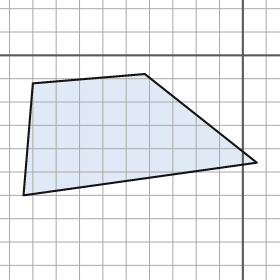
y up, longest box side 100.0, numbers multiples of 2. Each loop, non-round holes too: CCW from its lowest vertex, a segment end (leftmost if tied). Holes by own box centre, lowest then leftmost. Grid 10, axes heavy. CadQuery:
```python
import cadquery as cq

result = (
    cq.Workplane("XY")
    .moveTo(-94.0, -60.0)
    .lineTo(6.0, -46.0)
    .lineTo(-42.0, -8.0)
    .lineTo(-90.0, -12.0)
    .close()
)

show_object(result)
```